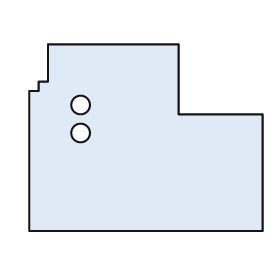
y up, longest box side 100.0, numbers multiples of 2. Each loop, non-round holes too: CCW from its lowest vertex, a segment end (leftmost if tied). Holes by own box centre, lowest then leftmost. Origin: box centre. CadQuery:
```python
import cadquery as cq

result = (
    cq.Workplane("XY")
    .moveTo(-50.0, -40.0)
    .lineTo(50.0, -40.0)
    .lineTo(50.0, 10.0)
    .lineTo(14.0, 10.0)
    .lineTo(14.0, 40.0)
    .lineTo(-42.0, 40.0)
    .lineTo(-42.0, 24.0)
    .lineTo(-46.0, 24.0)
    .lineTo(-46.0, 20.0)
    .lineTo(-50.0, 20.0)
    .close()
    .moveTo(-28.0, 2.0)
    .circle(4.0)
    .moveTo(-28.0, 14.0)
    .circle(4.0)
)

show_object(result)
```